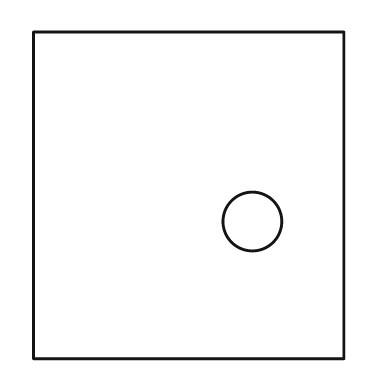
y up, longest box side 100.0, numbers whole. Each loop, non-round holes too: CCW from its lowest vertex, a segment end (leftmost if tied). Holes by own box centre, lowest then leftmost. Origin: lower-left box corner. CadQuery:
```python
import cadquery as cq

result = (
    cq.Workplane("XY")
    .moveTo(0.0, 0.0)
    .lineTo(95.0, 0.0)
    .lineTo(95.0, 100.0)
    .lineTo(0.0, 100.0)
    .close()
    .moveTo(67.0, 42.0)
    .circle(9.0)
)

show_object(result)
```